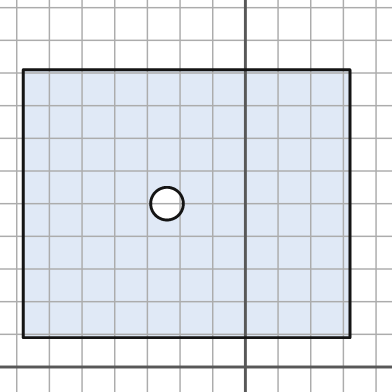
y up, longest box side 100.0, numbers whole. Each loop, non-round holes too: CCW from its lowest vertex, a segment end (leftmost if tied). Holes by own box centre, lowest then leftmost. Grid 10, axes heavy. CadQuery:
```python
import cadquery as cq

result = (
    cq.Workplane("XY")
    .moveTo(-68.0, 9.0)
    .lineTo(32.0, 9.0)
    .lineTo(32.0, 91.0)
    .lineTo(-68.0, 91.0)
    .close()
    .moveTo(-24.0, 50.0)
    .circle(5.0)
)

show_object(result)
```